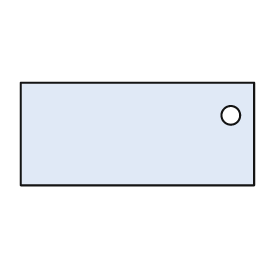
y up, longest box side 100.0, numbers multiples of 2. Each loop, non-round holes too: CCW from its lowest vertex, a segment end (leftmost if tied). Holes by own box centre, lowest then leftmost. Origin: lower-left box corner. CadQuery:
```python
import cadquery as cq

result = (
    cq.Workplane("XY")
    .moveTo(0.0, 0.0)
    .lineTo(100.0, 0.0)
    .lineTo(100.0, 44.0)
    .lineTo(0.0, 44.0)
    .close()
    .moveTo(90.0, 30.0)
    .circle(4.0)
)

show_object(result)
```